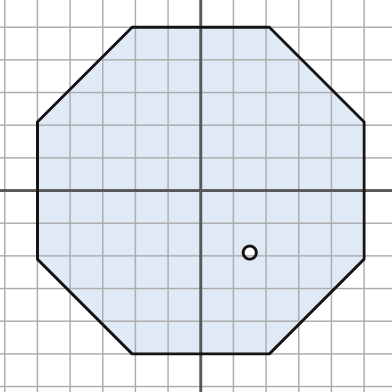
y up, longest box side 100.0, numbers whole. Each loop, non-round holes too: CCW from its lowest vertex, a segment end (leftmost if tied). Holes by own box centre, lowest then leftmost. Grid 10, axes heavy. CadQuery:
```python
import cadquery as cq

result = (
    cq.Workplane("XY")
    .moveTo(-21.0, -50.0)
    .lineTo(21.0, -50.0)
    .lineTo(50.0, -21.0)
    .lineTo(50.0, 21.0)
    .lineTo(21.0, 50.0)
    .lineTo(-21.0, 50.0)
    .lineTo(-50.0, 21.0)
    .lineTo(-50.0, -21.0)
    .close()
    .moveTo(15.0, -19.0)
    .circle(2.0)
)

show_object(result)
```